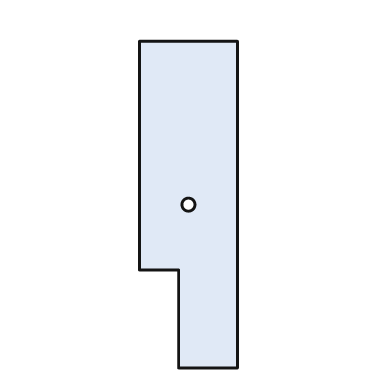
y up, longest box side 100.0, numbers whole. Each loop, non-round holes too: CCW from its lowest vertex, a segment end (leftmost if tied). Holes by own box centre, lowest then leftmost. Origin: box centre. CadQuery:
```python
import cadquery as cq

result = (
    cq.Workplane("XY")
    .moveTo(-3.0, -50.0)
    .lineTo(15.0, -50.0)
    .lineTo(15.0, 50.0)
    .lineTo(-15.0, 50.0)
    .lineTo(-15.0, -20.0)
    .lineTo(-3.0, -20.0)
    .close()
    .moveTo(0.0, 0.0)
    .circle(2.0)
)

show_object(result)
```